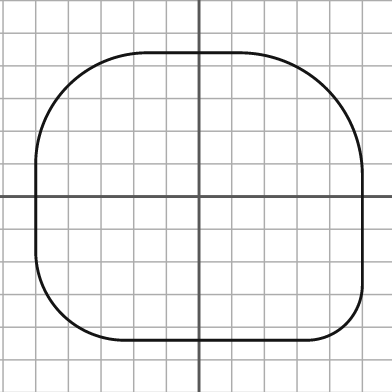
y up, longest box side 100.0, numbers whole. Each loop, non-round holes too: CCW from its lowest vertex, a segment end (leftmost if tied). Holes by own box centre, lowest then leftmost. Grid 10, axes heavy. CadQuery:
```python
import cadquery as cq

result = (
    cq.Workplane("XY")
    .moveTo(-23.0, -44.0)
    .lineTo(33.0, -44.0)
    .threePointArc((45.0, -39.0), (50.0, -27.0))
    .lineTo(50.0, 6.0)
    .threePointArc((39.0, 33.0), (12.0, 44.0))
    .lineTo(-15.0, 44.0)
    .threePointArc((-40.0, 34.0), (-50.0, 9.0))
    .lineTo(-50.0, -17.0)
    .threePointArc((-42.0, -36.0), (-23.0, -44.0))
    .close()
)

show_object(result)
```